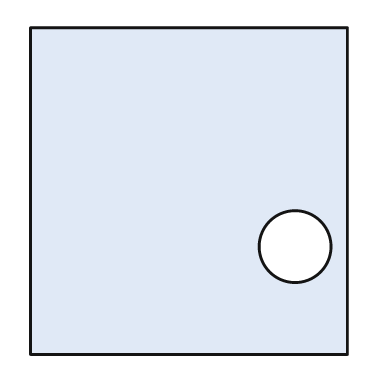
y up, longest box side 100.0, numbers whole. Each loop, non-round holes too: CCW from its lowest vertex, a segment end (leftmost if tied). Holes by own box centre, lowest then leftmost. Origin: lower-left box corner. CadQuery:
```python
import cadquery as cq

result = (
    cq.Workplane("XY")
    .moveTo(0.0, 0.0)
    .lineTo(97.0, 0.0)
    .lineTo(97.0, 100.0)
    .lineTo(0.0, 100.0)
    .close()
    .moveTo(81.0, 33.0)
    .circle(11.0)
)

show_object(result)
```